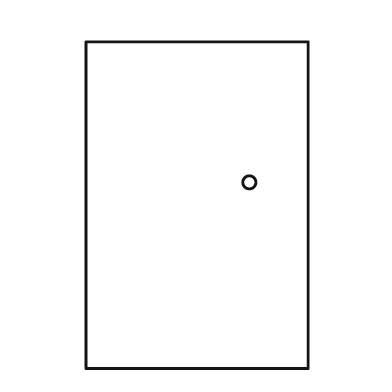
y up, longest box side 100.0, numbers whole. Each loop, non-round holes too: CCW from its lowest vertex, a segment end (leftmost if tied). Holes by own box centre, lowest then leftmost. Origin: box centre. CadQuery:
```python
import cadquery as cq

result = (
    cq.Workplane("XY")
    .moveTo(-34.0, -50.0)
    .lineTo(34.0, -50.0)
    .lineTo(34.0, 50.0)
    .lineTo(-34.0, 50.0)
    .close()
    .moveTo(16.0, 7.0)
    .circle(2.0)
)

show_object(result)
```